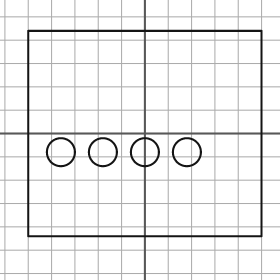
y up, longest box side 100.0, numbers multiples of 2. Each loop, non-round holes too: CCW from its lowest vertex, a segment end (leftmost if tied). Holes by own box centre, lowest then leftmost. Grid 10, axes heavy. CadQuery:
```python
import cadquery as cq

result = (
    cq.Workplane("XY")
    .moveTo(-50.0, -44.0)
    .lineTo(50.0, -44.0)
    .lineTo(50.0, 44.0)
    .lineTo(-50.0, 44.0)
    .close()
    .moveTo(-36.0, -8.0)
    .circle(6.0)
    .moveTo(-18.0, -8.0)
    .circle(6.0)
    .moveTo(0.0, -8.0)
    .circle(6.0)
    .moveTo(18.0, -8.0)
    .circle(6.0)
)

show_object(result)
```